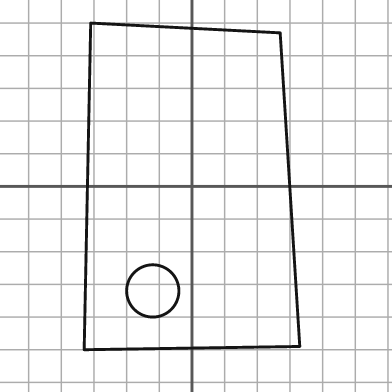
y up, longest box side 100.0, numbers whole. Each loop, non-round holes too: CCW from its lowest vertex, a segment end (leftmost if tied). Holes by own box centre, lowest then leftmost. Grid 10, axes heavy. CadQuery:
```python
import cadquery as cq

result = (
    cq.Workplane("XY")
    .moveTo(-33.0, -50.0)
    .lineTo(33.0, -49.0)
    .lineTo(27.0, 47.0)
    .lineTo(-31.0, 50.0)
    .close()
    .moveTo(-12.0, -32.0)
    .circle(8.0)
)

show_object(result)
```